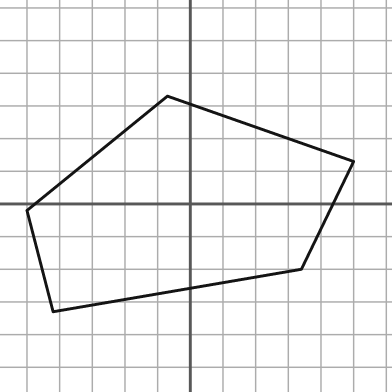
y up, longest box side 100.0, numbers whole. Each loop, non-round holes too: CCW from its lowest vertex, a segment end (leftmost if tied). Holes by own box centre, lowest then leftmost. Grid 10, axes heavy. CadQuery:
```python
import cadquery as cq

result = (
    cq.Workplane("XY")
    .moveTo(-42.0, -33.0)
    .lineTo(34.0, -20.0)
    .lineTo(50.0, 13.0)
    .lineTo(-7.0, 33.0)
    .lineTo(-50.0, -2.0)
    .close()
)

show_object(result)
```